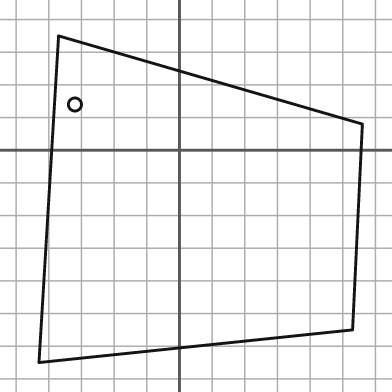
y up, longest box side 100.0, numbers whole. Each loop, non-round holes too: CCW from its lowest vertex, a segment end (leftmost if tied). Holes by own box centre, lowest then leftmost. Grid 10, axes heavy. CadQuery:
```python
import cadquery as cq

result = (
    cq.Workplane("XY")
    .moveTo(-43.0, -65.0)
    .lineTo(53.0, -55.0)
    .lineTo(56.0, 8.0)
    .lineTo(-37.0, 35.0)
    .close()
    .moveTo(-32.0, 14.0)
    .circle(2.0)
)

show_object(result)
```